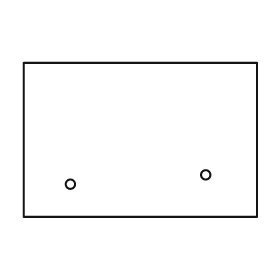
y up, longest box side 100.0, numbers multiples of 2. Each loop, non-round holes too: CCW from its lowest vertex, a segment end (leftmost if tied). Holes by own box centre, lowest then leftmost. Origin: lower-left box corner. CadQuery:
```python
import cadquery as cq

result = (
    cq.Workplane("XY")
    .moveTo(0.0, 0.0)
    .lineTo(100.0, 0.0)
    .lineTo(100.0, 66.0)
    .lineTo(0.0, 66.0)
    .close()
    .moveTo(20.0, 14.0)
    .circle(2.0)
    .moveTo(78.0, 18.0)
    .circle(2.0)
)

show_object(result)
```